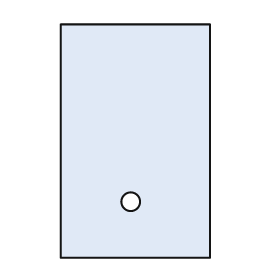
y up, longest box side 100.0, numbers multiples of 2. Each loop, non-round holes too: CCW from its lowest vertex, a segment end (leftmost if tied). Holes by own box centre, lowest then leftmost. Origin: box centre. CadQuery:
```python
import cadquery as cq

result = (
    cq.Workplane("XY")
    .moveTo(-32.0, -50.0)
    .lineTo(32.0, -50.0)
    .lineTo(32.0, 50.0)
    .lineTo(-32.0, 50.0)
    .close()
    .moveTo(-2.0, -26.0)
    .circle(4.0)
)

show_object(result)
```